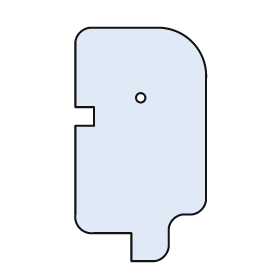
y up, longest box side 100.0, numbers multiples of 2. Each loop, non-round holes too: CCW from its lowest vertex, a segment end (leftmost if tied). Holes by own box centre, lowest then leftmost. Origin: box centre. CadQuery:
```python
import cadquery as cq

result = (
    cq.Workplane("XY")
    .moveTo(-4.0, -50.0)
    .lineTo(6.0, -50.0)
    .threePointArc((10.0, -48.0), (12.0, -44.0))
    .lineTo(12.0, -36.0)
    .threePointArc((14.0, -32.0), (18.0, -30.0))
    .lineTo(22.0, -30.0)
    .threePointArc((26.0, -28.0), (28.0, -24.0))
    .lineTo(28.0, 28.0)
    .threePointArc((22.0, 44.0), (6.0, 50.0))
    .lineTo(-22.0, 50.0)
    .threePointArc((-26.0, 48.0), (-28.0, 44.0))
    .lineTo(-28.0, 16.0)
    .lineTo(-20.0, 16.0)
    .lineTo(-20.0, 8.0)
    .lineTo(-28.0, 8.0)
    .lineTo(-28.0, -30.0)
    .threePointArc((-26.0, -36.0), (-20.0, -38.0))
    .lineTo(-4.0, -38.0)
    .close()
    .moveTo(0.0, 20.0)
    .circle(2.0)
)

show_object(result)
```